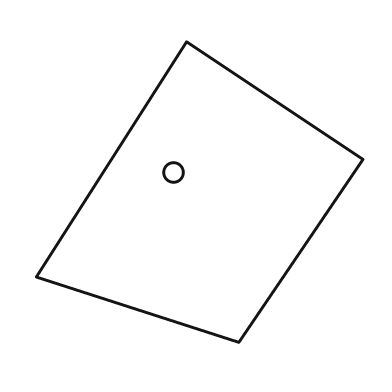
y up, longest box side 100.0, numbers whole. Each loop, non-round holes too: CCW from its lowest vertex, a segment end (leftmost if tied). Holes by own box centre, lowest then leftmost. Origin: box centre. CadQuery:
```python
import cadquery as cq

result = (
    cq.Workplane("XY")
    .moveTo(12.0, -46.0)
    .lineTo(50.0, 10.0)
    .lineTo(-4.0, 46.0)
    .lineTo(-50.0, -26.0)
    .close()
    .moveTo(-8.0, 6.0)
    .circle(3.0)
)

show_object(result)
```